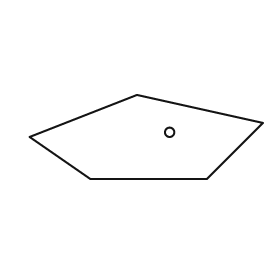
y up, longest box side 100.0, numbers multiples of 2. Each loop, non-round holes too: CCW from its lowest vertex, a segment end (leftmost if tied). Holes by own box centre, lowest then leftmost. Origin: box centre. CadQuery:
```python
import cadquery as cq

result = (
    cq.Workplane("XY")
    .moveTo(-24.0, -18.0)
    .lineTo(26.0, -18.0)
    .lineTo(50.0, 6.0)
    .lineTo(-4.0, 18.0)
    .lineTo(-50.0, 0.0)
    .close()
    .moveTo(10.0, 2.0)
    .circle(2.0)
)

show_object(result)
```